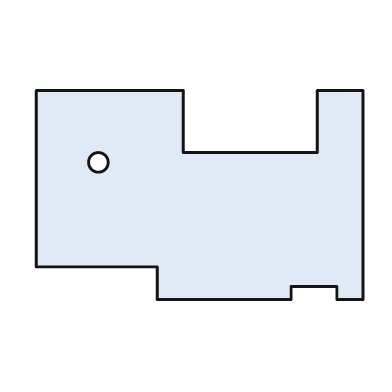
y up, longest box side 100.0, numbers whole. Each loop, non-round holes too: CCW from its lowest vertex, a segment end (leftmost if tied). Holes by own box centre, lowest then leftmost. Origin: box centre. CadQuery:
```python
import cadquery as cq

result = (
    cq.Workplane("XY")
    .moveTo(-13.0, -32.0)
    .lineTo(28.0, -32.0)
    .lineTo(28.0, -28.0)
    .lineTo(42.0, -28.0)
    .lineTo(42.0, -32.0)
    .lineTo(50.0, -32.0)
    .lineTo(50.0, 32.0)
    .lineTo(36.0, 32.0)
    .lineTo(36.0, 13.0)
    .lineTo(-5.0, 13.0)
    .lineTo(-5.0, 32.0)
    .lineTo(-50.0, 32.0)
    .lineTo(-50.0, -22.0)
    .lineTo(-13.0, -22.0)
    .close()
    .moveTo(-31.0, 10.0)
    .circle(3.0)
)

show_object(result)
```